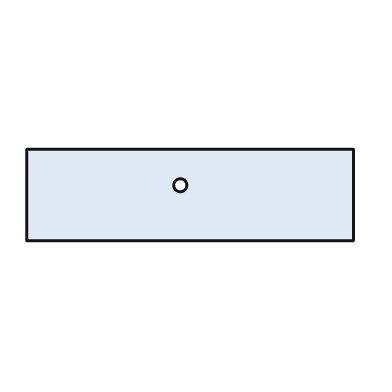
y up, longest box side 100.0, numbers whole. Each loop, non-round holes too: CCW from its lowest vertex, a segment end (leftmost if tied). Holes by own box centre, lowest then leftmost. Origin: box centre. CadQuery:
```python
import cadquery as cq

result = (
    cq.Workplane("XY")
    .moveTo(-50.0, -14.0)
    .lineTo(50.0, -14.0)
    .lineTo(50.0, 14.0)
    .lineTo(-50.0, 14.0)
    .close()
    .moveTo(-3.0, 3.0)
    .circle(2.0)
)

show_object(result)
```